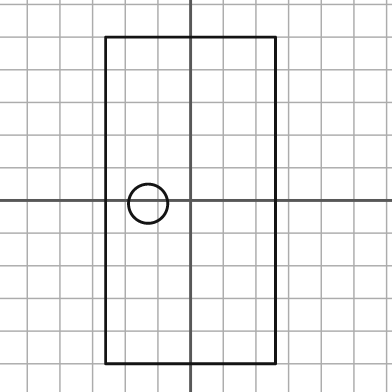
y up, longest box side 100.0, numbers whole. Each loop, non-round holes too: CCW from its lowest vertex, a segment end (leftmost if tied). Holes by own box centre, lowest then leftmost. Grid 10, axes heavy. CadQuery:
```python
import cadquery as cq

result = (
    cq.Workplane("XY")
    .moveTo(-26.0, -50.0)
    .lineTo(26.0, -50.0)
    .lineTo(26.0, 50.0)
    .lineTo(-26.0, 50.0)
    .close()
    .moveTo(-13.0, -1.0)
    .circle(6.0)
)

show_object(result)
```